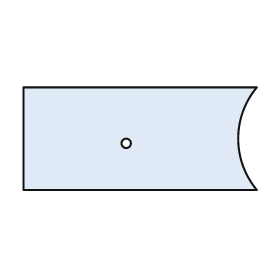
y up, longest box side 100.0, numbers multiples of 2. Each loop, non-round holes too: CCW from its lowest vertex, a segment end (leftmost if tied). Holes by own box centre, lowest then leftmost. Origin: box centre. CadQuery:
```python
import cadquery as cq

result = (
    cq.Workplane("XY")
    .moveTo(-50.0, -22.0)
    .lineTo(50.0, -22.0)
    .threePointArc((42.0, 0.0), (50.0, 22.0))
    .lineTo(-50.0, 22.0)
    .close()
    .moveTo(-6.0, -2.0)
    .circle(2.0)
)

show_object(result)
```